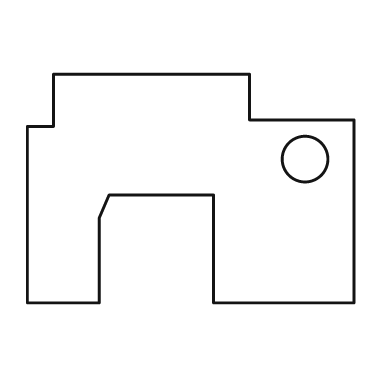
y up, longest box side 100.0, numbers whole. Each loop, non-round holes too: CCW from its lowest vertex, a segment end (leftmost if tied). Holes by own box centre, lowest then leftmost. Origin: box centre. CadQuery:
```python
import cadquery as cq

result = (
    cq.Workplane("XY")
    .moveTo(-50.0, -35.0)
    .lineTo(-28.0, -35.0)
    .lineTo(-28.0, -9.0)
    .lineTo(-25.0, -2.0)
    .lineTo(7.0, -2.0)
    .lineTo(7.0, -35.0)
    .lineTo(50.0, -35.0)
    .lineTo(50.0, 21.0)
    .lineTo(18.0, 21.0)
    .lineTo(18.0, 35.0)
    .lineTo(-42.0, 35.0)
    .lineTo(-42.0, 19.0)
    .lineTo(-50.0, 19.0)
    .close()
    .moveTo(35.0, 9.0)
    .circle(7.0)
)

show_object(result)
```